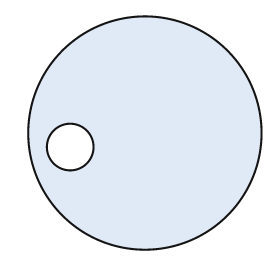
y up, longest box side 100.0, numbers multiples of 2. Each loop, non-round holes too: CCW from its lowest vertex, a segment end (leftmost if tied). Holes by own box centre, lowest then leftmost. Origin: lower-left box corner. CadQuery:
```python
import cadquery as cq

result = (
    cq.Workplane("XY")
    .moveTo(50.0, 50.0)
    .circle(50.0)
    .moveTo(18.0, 44.0)
    .circle(10.0)
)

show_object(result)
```